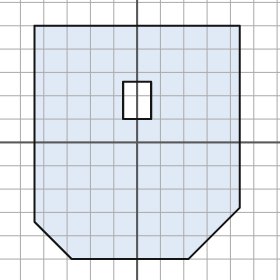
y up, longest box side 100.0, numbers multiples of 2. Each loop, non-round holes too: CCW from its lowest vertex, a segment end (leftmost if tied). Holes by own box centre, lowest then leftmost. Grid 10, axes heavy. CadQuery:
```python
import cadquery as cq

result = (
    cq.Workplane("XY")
    .moveTo(-28.0, -50.0)
    .lineTo(22.0, -50.0)
    .lineTo(44.0, -28.0)
    .lineTo(44.0, 50.0)
    .lineTo(-44.0, 50.0)
    .lineTo(-44.0, -34.0)
    .close()
    .moveTo(-6.0, 10.0)
    .lineTo(6.0, 10.0)
    .lineTo(6.0, 26.0)
    .lineTo(-6.0, 26.0)
    .close()
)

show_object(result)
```